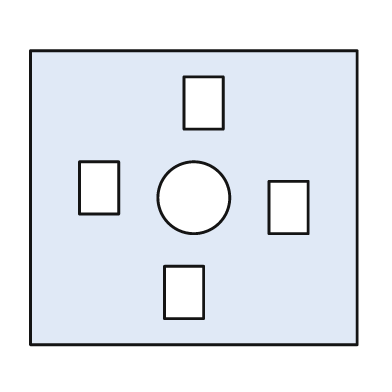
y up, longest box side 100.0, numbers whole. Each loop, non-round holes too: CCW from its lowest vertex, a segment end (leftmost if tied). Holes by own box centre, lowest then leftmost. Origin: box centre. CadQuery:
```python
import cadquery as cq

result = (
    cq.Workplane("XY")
    .moveTo(-50.0, -45.0)
    .lineTo(50.0, -45.0)
    .lineTo(50.0, 45.0)
    .lineTo(-50.0, 45.0)
    .close()
    .moveTo(-9.0, -37.0)
    .lineTo(3.0, -37.0)
    .lineTo(3.0, -21.0)
    .lineTo(-9.0, -21.0)
    .close()
    .moveTo(23.0, -11.0)
    .lineTo(35.0, -11.0)
    .lineTo(35.0, 5.0)
    .lineTo(23.0, 5.0)
    .close()
    .moveTo(0.0, 0.0)
    .circle(11.0)
    .moveTo(-35.0, -5.0)
    .lineTo(-23.0, -5.0)
    .lineTo(-23.0, 11.0)
    .lineTo(-35.0, 11.0)
    .close()
    .moveTo(-3.0, 21.0)
    .lineTo(9.0, 21.0)
    .lineTo(9.0, 37.0)
    .lineTo(-3.0, 37.0)
    .close()
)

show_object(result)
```